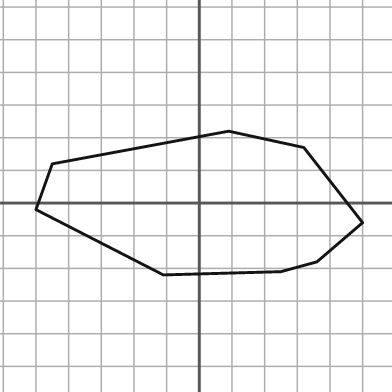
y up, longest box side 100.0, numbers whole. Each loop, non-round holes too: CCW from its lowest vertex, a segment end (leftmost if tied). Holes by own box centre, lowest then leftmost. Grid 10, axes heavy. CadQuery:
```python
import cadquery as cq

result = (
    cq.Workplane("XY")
    .moveTo(-11.0, -22.0)
    .lineTo(25.0, -21.0)
    .lineTo(36.0, -18.0)
    .lineTo(50.0, -6.0)
    .lineTo(32.0, 17.0)
    .lineTo(9.0, 22.0)
    .lineTo(-45.0, 12.0)
    .lineTo(-50.0, -2.0)
    .close()
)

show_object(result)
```